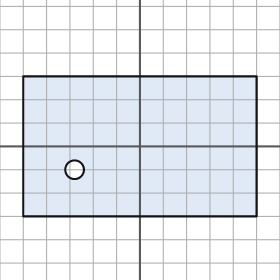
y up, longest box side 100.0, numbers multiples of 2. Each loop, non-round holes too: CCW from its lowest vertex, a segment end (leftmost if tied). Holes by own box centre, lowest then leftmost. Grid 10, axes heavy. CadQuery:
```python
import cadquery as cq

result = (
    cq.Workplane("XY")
    .moveTo(-50.0, -30.0)
    .lineTo(50.0, -30.0)
    .lineTo(50.0, 30.0)
    .lineTo(-50.0, 30.0)
    .close()
    .moveTo(-28.0, -10.0)
    .circle(4.0)
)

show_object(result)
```